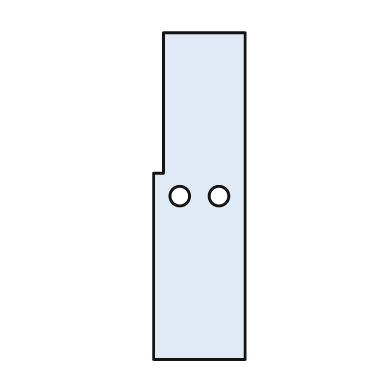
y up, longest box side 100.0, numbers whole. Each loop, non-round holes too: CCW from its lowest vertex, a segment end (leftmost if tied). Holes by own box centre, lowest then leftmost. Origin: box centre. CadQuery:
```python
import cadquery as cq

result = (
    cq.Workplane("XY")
    .moveTo(-14.0, -50.0)
    .lineTo(14.0, -50.0)
    .lineTo(14.0, 50.0)
    .lineTo(-11.0, 50.0)
    .lineTo(-11.0, 7.0)
    .lineTo(-14.0, 7.0)
    .close()
    .moveTo(-6.0, 0.0)
    .circle(3.0)
    .moveTo(6.0, 0.0)
    .circle(3.0)
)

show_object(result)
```